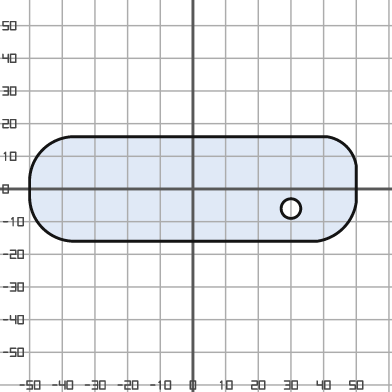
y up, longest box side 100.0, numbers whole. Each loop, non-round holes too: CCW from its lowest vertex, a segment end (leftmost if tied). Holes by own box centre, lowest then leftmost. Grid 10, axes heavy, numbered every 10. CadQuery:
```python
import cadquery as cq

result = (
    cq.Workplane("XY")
    .moveTo(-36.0, -16.0)
    .lineTo(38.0, -16.0)
    .threePointArc((46.0, -12.0), (50.0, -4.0))
    .lineTo(50.0, 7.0)
    .threePointArc((47.0, 13.0), (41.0, 16.0))
    .lineTo(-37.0, 16.0)
    .threePointArc((-46.0, 12.0), (-50.0, 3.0))
    .lineTo(-50.0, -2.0)
    .threePointArc((-46.0, -12.0), (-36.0, -16.0))
    .close()
    .moveTo(30.0, -6.0)
    .circle(3.0)
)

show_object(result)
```